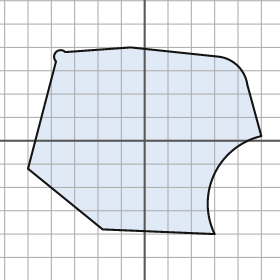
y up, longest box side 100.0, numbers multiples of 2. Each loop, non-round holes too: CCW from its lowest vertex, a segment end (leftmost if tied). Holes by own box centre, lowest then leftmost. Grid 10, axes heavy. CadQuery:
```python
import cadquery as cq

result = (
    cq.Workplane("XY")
    .moveTo(30.0, -40.0)
    .threePointArc((30.0, -14.0), (50.0, 2.0))
    .lineTo(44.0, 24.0)
    .threePointArc((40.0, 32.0), (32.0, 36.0))
    .lineTo(-6.0, 40.0)
    .lineTo(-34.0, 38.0)
    .threePointArc((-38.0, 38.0), (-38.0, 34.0))
    .lineTo(-50.0, -12.0)
    .lineTo(-18.0, -38.0)
    .close()
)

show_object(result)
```